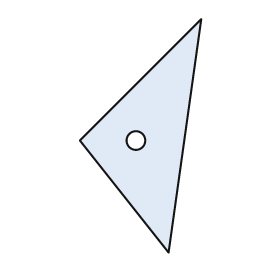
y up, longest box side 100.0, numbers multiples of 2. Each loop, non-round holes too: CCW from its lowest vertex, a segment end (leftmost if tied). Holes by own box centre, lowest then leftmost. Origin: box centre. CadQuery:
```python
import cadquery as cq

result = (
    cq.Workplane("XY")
    .moveTo(12.0, -50.0)
    .lineTo(26.0, 50.0)
    .lineTo(-26.0, -2.0)
    .close()
    .moveTo(-2.0, -2.0)
    .circle(4.0)
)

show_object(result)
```